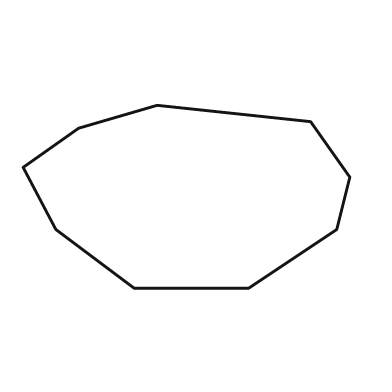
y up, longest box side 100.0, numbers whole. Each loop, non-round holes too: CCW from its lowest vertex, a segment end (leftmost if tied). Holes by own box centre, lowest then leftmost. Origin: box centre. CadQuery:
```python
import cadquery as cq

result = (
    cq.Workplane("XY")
    .moveTo(-16.0, -28.0)
    .lineTo(19.0, -28.0)
    .lineTo(46.0, -10.0)
    .lineTo(50.0, 6.0)
    .lineTo(38.0, 23.0)
    .lineTo(-9.0, 28.0)
    .lineTo(-33.0, 21.0)
    .lineTo(-50.0, 9.0)
    .lineTo(-40.0, -10.0)
    .close()
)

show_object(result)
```